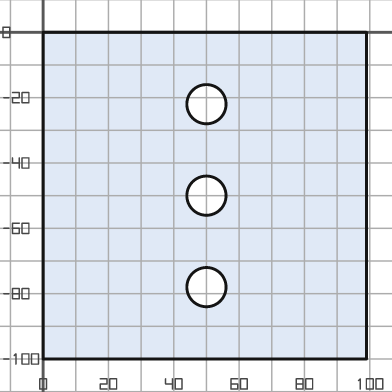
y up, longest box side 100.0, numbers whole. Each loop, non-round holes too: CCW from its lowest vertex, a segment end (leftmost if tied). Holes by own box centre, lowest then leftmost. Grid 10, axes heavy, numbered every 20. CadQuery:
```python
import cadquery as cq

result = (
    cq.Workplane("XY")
    .moveTo(0.0, -100.0)
    .lineTo(99.0, -100.0)
    .lineTo(99.0, 0.0)
    .lineTo(0.0, 0.0)
    .close()
    .moveTo(50.0, -78.0)
    .circle(6.0)
    .moveTo(50.0, -50.0)
    .circle(6.0)
    .moveTo(50.0, -22.0)
    .circle(6.0)
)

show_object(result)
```